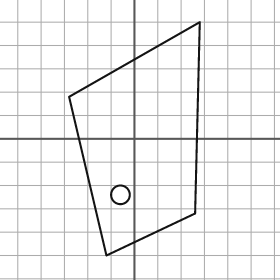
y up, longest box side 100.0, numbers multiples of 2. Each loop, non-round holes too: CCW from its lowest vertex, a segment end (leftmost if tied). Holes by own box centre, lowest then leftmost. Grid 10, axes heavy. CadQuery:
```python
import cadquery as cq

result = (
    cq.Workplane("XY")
    .moveTo(-12.0, -50.0)
    .lineTo(26.0, -32.0)
    .lineTo(28.0, 50.0)
    .lineTo(-28.0, 18.0)
    .close()
    .moveTo(-6.0, -24.0)
    .circle(4.0)
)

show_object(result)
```